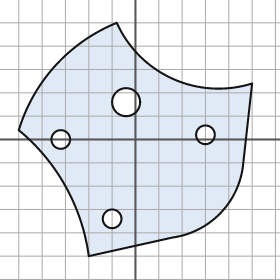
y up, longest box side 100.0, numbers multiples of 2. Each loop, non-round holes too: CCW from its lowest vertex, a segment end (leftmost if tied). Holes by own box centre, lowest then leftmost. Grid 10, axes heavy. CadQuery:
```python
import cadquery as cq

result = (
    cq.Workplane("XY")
    .moveTo(-20.0, -50.0)
    .lineTo(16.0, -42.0)
    .threePointArc((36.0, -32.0), (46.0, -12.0))
    .lineTo(50.0, 24.0)
    .threePointArc((16.0, 26.0), (-8.0, 50.0))
    .threePointArc((-34.0, 32.0), (-50.0, 4.0))
    .threePointArc((-30.0, -20.0), (-20.0, -50.0))
    .close()
    .moveTo(-10.0, -34.0)
    .circle(4.0)
    .moveTo(-32.0, 0.0)
    .circle(4.0)
    .moveTo(30.0, 2.0)
    .circle(4.0)
    .moveTo(-4.0, 16.0)
    .circle(6.0)
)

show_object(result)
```